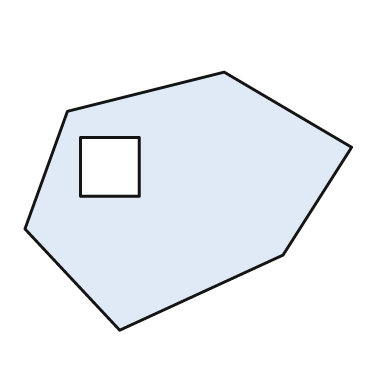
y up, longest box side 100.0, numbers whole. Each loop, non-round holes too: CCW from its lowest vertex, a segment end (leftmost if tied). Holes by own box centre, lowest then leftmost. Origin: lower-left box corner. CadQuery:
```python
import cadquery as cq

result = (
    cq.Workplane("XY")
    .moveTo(29.0, 0.0)
    .lineTo(79.0, 23.0)
    .lineTo(100.0, 56.0)
    .lineTo(61.0, 79.0)
    .lineTo(13.0, 67.0)
    .lineTo(0.0, 31.0)
    .close()
    .moveTo(17.0, 41.0)
    .lineTo(35.0, 41.0)
    .lineTo(35.0, 59.0)
    .lineTo(17.0, 59.0)
    .close()
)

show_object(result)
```